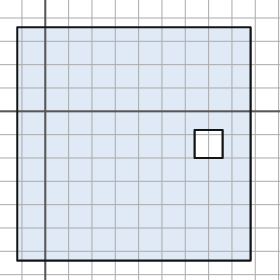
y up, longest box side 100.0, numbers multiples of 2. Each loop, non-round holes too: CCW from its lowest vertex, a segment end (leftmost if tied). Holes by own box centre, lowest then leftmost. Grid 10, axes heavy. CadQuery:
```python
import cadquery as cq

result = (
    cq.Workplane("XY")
    .moveTo(-12.0, -64.0)
    .lineTo(88.0, -64.0)
    .lineTo(88.0, 36.0)
    .lineTo(-12.0, 36.0)
    .close()
    .moveTo(64.0, -20.0)
    .lineTo(76.0, -20.0)
    .lineTo(76.0, -8.0)
    .lineTo(64.0, -8.0)
    .close()
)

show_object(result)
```